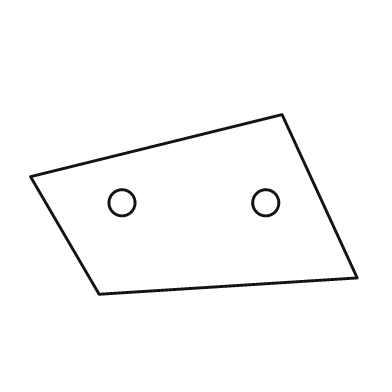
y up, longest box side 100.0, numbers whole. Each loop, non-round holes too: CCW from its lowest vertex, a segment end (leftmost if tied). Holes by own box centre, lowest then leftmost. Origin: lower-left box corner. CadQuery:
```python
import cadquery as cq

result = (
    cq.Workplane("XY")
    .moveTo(21.0, 0.0)
    .lineTo(100.0, 5.0)
    .lineTo(77.0, 55.0)
    .lineTo(0.0, 36.0)
    .close()
    .moveTo(28.0, 28.0)
    .circle(4.0)
    .moveTo(72.0, 28.0)
    .circle(4.0)
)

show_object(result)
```